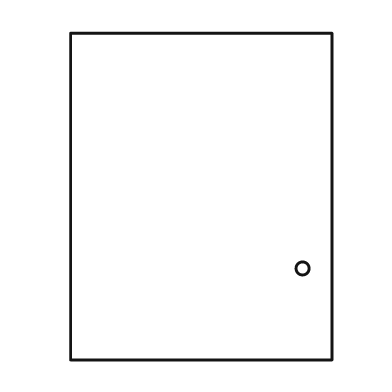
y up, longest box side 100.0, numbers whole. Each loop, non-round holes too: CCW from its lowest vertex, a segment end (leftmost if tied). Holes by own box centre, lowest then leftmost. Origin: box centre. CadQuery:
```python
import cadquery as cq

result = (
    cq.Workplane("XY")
    .moveTo(-40.0, -50.0)
    .lineTo(40.0, -50.0)
    .lineTo(40.0, 50.0)
    .lineTo(-40.0, 50.0)
    .close()
    .moveTo(31.0, -22.0)
    .circle(2.0)
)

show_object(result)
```